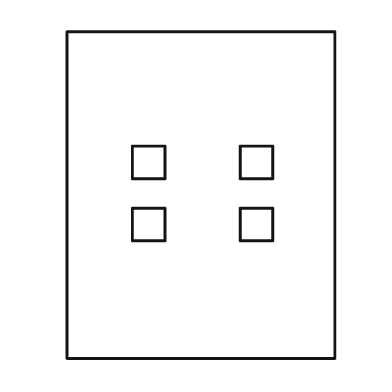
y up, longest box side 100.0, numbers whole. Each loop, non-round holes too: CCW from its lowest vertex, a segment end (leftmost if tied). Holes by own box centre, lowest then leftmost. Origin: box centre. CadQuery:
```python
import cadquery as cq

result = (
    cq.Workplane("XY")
    .moveTo(-41.0, -50.0)
    .lineTo(41.0, -50.0)
    .lineTo(41.0, 50.0)
    .lineTo(-41.0, 50.0)
    .close()
    .moveTo(-21.0, -14.0)
    .lineTo(-11.0, -14.0)
    .lineTo(-11.0, -4.0)
    .lineTo(-21.0, -4.0)
    .close()
    .moveTo(12.0, -14.0)
    .lineTo(22.0, -14.0)
    .lineTo(22.0, -4.0)
    .lineTo(12.0, -4.0)
    .close()
    .moveTo(-21.0, 5.0)
    .lineTo(-11.0, 5.0)
    .lineTo(-11.0, 15.0)
    .lineTo(-21.0, 15.0)
    .close()
    .moveTo(12.0, 5.0)
    .lineTo(22.0, 5.0)
    .lineTo(22.0, 15.0)
    .lineTo(12.0, 15.0)
    .close()
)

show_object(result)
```